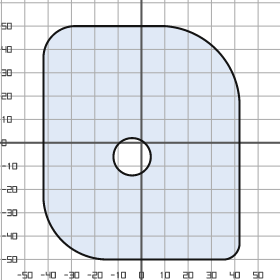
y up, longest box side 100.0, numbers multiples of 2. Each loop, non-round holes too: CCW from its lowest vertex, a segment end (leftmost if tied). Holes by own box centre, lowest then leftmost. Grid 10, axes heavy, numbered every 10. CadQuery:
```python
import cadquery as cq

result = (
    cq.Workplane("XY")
    .moveTo(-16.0, -50.0)
    .lineTo(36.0, -50.0)
    .threePointArc((40.0, -48.0), (42.0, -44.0))
    .lineTo(42.0, 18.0)
    .threePointArc((32.0, 40.0), (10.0, 50.0))
    .lineTo(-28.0, 50.0)
    .threePointArc((-38.0, 46.0), (-42.0, 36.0))
    .lineTo(-42.0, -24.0)
    .threePointArc((-34.0, -42.0), (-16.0, -50.0))
    .close()
    .moveTo(-4.0, -6.0)
    .circle(8.0)
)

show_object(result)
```